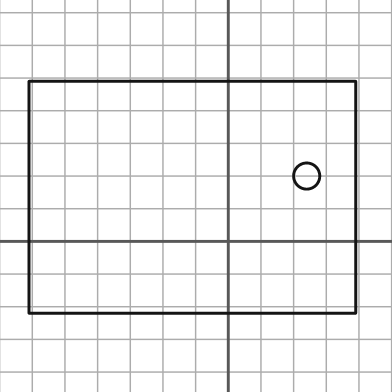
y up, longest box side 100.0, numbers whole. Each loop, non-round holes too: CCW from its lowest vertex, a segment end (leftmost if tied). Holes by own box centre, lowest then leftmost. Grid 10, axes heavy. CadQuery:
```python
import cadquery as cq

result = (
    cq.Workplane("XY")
    .moveTo(-61.0, -22.0)
    .lineTo(39.0, -22.0)
    .lineTo(39.0, 49.0)
    .lineTo(-61.0, 49.0)
    .close()
    .moveTo(24.0, 20.0)
    .circle(4.0)
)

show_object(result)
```